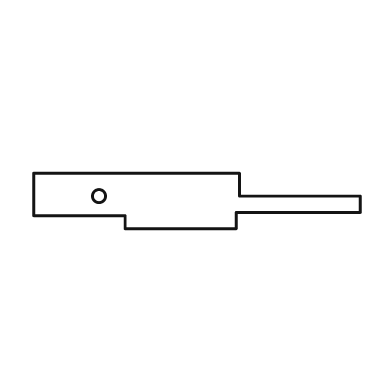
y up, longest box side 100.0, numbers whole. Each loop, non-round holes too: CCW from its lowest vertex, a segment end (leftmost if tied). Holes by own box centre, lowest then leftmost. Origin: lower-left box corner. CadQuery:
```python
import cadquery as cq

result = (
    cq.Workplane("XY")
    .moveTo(28.0, 0.0)
    .lineTo(62.0, 0.0)
    .lineTo(62.0, 5.0)
    .lineTo(100.0, 5.0)
    .lineTo(100.0, 10.0)
    .lineTo(63.0, 10.0)
    .lineTo(63.0, 17.0)
    .lineTo(0.0, 17.0)
    .lineTo(0.0, 4.0)
    .lineTo(28.0, 4.0)
    .close()
    .moveTo(20.0, 10.0)
    .circle(2.0)
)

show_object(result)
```